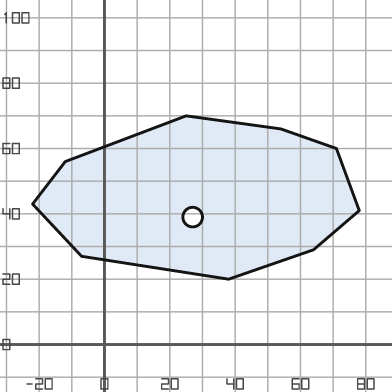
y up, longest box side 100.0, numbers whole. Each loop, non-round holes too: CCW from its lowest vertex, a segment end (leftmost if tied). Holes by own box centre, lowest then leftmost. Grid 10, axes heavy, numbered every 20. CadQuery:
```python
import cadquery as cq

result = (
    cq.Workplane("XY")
    .moveTo(38.0, 20.0)
    .lineTo(64.0, 29.0)
    .lineTo(78.0, 41.0)
    .lineTo(71.0, 60.0)
    .lineTo(54.0, 66.0)
    .lineTo(25.0, 70.0)
    .lineTo(-12.0, 56.0)
    .lineTo(-22.0, 43.0)
    .lineTo(-7.0, 27.0)
    .close()
    .moveTo(27.0, 39.0)
    .circle(3.0)
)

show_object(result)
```